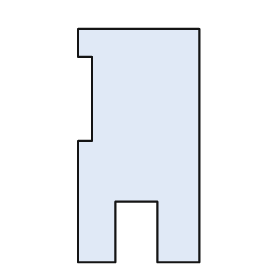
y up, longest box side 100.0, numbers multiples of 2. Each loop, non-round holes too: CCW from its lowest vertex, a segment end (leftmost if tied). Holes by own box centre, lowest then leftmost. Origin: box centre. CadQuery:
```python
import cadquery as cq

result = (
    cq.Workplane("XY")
    .moveTo(-26.0, -50.0)
    .lineTo(-10.0, -50.0)
    .lineTo(-10.0, -24.0)
    .lineTo(8.0, -24.0)
    .lineTo(8.0, -50.0)
    .lineTo(26.0, -50.0)
    .lineTo(26.0, 50.0)
    .lineTo(-26.0, 50.0)
    .lineTo(-26.0, 38.0)
    .lineTo(-20.0, 38.0)
    .lineTo(-20.0, 2.0)
    .lineTo(-26.0, 2.0)
    .close()
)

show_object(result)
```